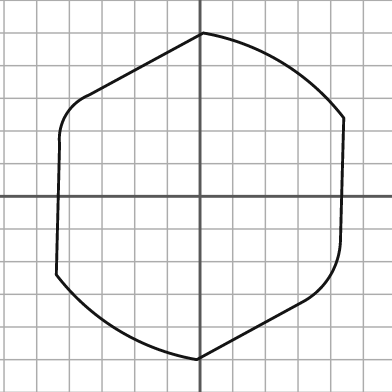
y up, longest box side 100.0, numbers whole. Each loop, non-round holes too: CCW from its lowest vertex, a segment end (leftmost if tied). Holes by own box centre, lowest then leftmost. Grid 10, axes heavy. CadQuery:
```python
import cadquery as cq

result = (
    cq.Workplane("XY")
    .moveTo(-1.0, -50.0)
    .lineTo(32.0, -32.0)
    .threePointArc((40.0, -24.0), (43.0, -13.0))
    .lineTo(44.0, 24.0)
    .threePointArc((25.0, 41.0), (1.0, 50.0))
    .lineTo(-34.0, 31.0)
    .threePointArc((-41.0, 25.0), (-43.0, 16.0))
    .lineTo(-44.0, -24.0)
    .threePointArc((-25.0, -41.0), (-1.0, -50.0))
    .close()
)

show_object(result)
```